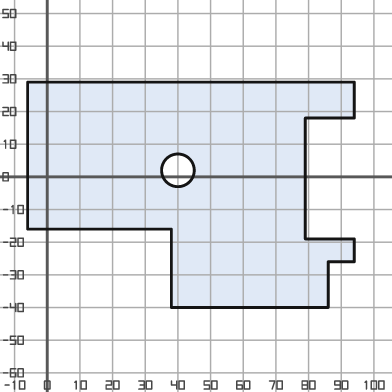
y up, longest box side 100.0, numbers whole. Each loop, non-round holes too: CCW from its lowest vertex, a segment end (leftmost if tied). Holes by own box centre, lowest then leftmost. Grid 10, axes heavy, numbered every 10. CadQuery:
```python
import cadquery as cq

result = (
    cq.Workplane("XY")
    .moveTo(38.0, -40.0)
    .lineTo(86.0, -40.0)
    .lineTo(86.0, -26.0)
    .lineTo(94.0, -26.0)
    .lineTo(94.0, -19.0)
    .lineTo(79.0, -19.0)
    .lineTo(79.0, 18.0)
    .lineTo(94.0, 18.0)
    .lineTo(94.0, 29.0)
    .lineTo(-6.0, 29.0)
    .lineTo(-6.0, -16.0)
    .lineTo(38.0, -16.0)
    .close()
    .moveTo(40.0, 2.0)
    .circle(5.0)
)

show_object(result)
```